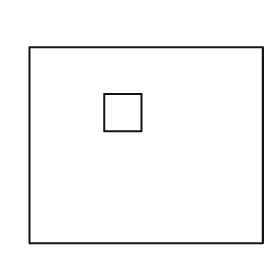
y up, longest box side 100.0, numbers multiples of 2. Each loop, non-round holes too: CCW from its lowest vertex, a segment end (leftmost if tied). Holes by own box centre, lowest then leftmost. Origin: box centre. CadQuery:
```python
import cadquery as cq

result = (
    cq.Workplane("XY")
    .moveTo(-50.0, -42.0)
    .lineTo(50.0, -42.0)
    .lineTo(50.0, 42.0)
    .lineTo(-50.0, 42.0)
    .close()
    .moveTo(-18.0, 6.0)
    .lineTo(-2.0, 6.0)
    .lineTo(-2.0, 22.0)
    .lineTo(-18.0, 22.0)
    .close()
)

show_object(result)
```